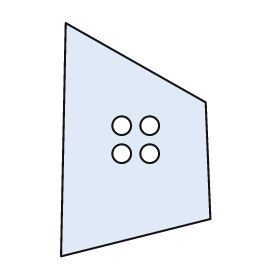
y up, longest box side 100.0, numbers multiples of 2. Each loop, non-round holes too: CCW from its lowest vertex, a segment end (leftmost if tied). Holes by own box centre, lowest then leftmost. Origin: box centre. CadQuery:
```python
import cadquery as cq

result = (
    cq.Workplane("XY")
    .moveTo(-32.0, -50.0)
    .lineTo(32.0, -34.0)
    .lineTo(30.0, 16.0)
    .lineTo(-30.0, 50.0)
    .close()
    .moveTo(-6.0, -6.0)
    .circle(4.0)
    .moveTo(6.0, -6.0)
    .circle(4.0)
    .moveTo(-6.0, 6.0)
    .circle(4.0)
    .moveTo(6.0, 6.0)
    .circle(4.0)
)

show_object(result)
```